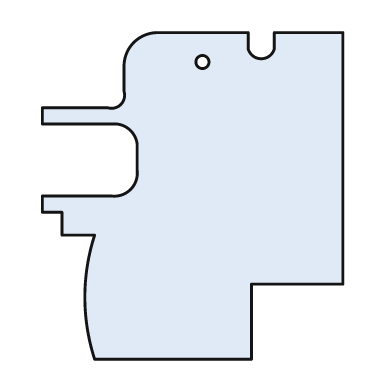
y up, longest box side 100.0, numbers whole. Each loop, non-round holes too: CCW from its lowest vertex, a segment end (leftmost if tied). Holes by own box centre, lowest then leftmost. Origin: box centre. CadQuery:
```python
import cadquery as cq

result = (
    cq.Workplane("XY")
    .moveTo(-30.0, -50.0)
    .lineTo(18.0, -50.0)
    .lineTo(18.0, -27.0)
    .lineTo(46.0, -27.0)
    .lineTo(46.0, 50.0)
    .lineTo(25.0, 50.0)
    .lineTo(25.0, 45.0)
    .threePointArc((21.0, 42.0), (17.0, 45.0))
    .lineTo(17.0, 50.0)
    .lineTo(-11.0, 50.0)
    .threePointArc((-18.0, 47.0), (-21.0, 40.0))
    .lineTo(-21.0, 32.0)
    .threePointArc((-22.0, 28.0), (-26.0, 27.0))
    .lineTo(-46.0, 27.0)
    .lineTo(-46.0, 22.0)
    .lineTo(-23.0, 22.0)
    .threePointArc((-19.0, 20.0), (-17.0, 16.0))
    .lineTo(-17.0, 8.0)
    .threePointArc((-19.0, 2.0), (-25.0, 0.0))
    .lineTo(-46.0, 0.0)
    .lineTo(-46.0, -5.0)
    .lineTo(-40.0, -5.0)
    .lineTo(-40.0, -12.0)
    .lineTo(-30.0, -12.0)
    .threePointArc((-33.0, -31.0), (-30.0, -50.0))
    .close()
    .moveTo(3.0, 41.0)
    .circle(2.0)
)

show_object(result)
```